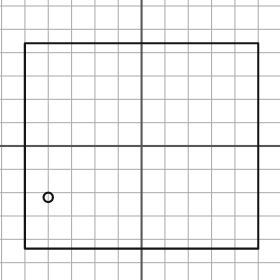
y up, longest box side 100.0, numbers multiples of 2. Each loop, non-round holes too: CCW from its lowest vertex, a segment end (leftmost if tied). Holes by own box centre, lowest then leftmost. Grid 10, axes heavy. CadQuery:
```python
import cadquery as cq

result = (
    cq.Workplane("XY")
    .moveTo(-50.0, -44.0)
    .lineTo(50.0, -44.0)
    .lineTo(50.0, 44.0)
    .lineTo(-50.0, 44.0)
    .close()
    .moveTo(-40.0, -22.0)
    .circle(2.0)
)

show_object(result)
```